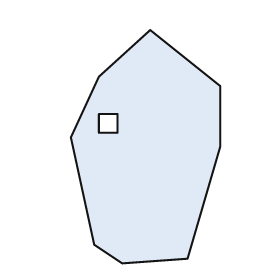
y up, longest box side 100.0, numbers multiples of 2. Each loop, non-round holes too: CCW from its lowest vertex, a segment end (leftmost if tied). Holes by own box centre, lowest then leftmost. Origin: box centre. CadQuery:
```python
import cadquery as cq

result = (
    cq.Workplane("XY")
    .moveTo(-10.0, -50.0)
    .lineTo(18.0, -48.0)
    .lineTo(32.0, 0.0)
    .lineTo(32.0, 26.0)
    .lineTo(2.0, 50.0)
    .lineTo(-20.0, 30.0)
    .lineTo(-32.0, 4.0)
    .lineTo(-22.0, -42.0)
    .close()
    .moveTo(-20.0, 6.0)
    .lineTo(-12.0, 6.0)
    .lineTo(-12.0, 14.0)
    .lineTo(-20.0, 14.0)
    .close()
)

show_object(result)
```